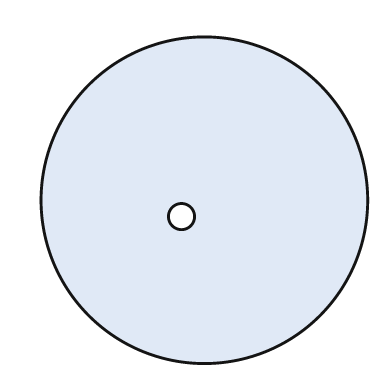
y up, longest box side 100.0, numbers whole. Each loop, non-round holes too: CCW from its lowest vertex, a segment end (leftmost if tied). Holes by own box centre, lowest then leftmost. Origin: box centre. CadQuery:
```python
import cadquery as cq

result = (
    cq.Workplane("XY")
    .moveTo(0.0, 0.0)
    .circle(50.0)
    .moveTo(-7.0, -5.0)
    .circle(4.0)
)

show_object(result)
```